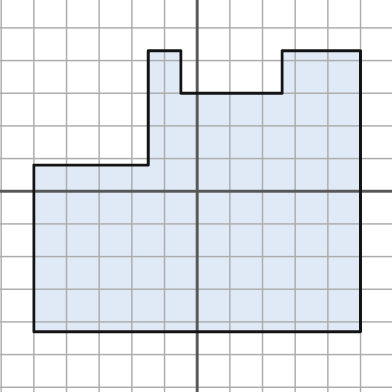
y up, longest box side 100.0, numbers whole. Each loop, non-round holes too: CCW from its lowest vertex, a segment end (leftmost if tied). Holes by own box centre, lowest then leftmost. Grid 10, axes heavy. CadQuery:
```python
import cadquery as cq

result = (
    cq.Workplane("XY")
    .moveTo(-50.0, -43.0)
    .lineTo(50.0, -43.0)
    .lineTo(50.0, 43.0)
    .lineTo(26.0, 43.0)
    .lineTo(26.0, 30.0)
    .lineTo(-5.0, 30.0)
    .lineTo(-5.0, 43.0)
    .lineTo(-15.0, 43.0)
    .lineTo(-15.0, 8.0)
    .lineTo(-50.0, 8.0)
    .close()
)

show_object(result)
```